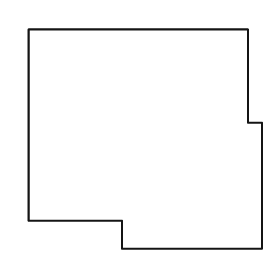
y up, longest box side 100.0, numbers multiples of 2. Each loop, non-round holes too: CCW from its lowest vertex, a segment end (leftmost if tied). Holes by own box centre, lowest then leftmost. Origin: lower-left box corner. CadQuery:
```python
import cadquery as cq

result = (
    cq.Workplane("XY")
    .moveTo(40.0, 0.0)
    .lineTo(100.0, 0.0)
    .lineTo(100.0, 54.0)
    .lineTo(94.0, 54.0)
    .lineTo(94.0, 94.0)
    .lineTo(0.0, 94.0)
    .lineTo(0.0, 12.0)
    .lineTo(40.0, 12.0)
    .close()
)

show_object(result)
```